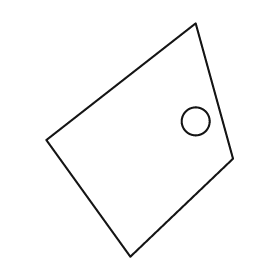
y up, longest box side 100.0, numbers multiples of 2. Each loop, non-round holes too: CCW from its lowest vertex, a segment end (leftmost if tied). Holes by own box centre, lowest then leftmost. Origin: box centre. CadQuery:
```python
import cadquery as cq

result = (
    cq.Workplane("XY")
    .moveTo(-4.0, -50.0)
    .lineTo(40.0, -8.0)
    .lineTo(24.0, 50.0)
    .lineTo(-40.0, 0.0)
    .close()
    .moveTo(24.0, 8.0)
    .circle(6.0)
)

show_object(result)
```